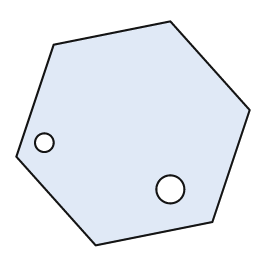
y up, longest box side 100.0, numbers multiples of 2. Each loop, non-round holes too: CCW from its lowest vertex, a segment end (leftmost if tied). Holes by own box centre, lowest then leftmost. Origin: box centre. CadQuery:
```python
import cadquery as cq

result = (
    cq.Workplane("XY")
    .moveTo(-16.0, -48.0)
    .lineTo(34.0, -38.0)
    .lineTo(50.0, 10.0)
    .lineTo(16.0, 48.0)
    .lineTo(-34.0, 38.0)
    .lineTo(-50.0, -10.0)
    .close()
    .moveTo(16.0, -24.0)
    .circle(6.0)
    .moveTo(-38.0, -4.0)
    .circle(4.0)
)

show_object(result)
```